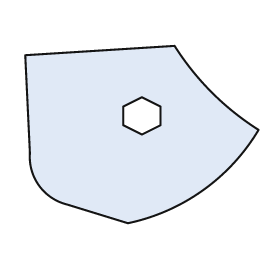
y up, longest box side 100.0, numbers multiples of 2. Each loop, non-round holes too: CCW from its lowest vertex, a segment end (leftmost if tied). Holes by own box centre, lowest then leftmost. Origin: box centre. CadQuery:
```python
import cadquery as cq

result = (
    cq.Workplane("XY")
    .moveTo(-6.0, -38.0)
    .threePointArc((26.0, -24.0), (50.0, 2.0))
    .threePointArc((30.0, 18.0), (14.0, 38.0))
    .lineTo(-50.0, 34.0)
    .lineTo(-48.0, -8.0)
    .threePointArc((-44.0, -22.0), (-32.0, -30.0))
    .close()
    .moveTo(0.0, 0.0)
    .lineTo(8.0, 4.0)
    .lineTo(8.0, 12.0)
    .lineTo(0.0, 16.0)
    .lineTo(-8.0, 12.0)
    .lineTo(-8.0, 4.0)
    .close()
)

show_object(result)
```